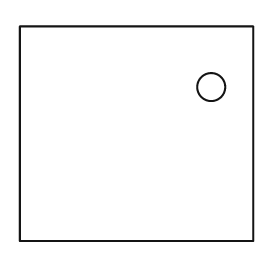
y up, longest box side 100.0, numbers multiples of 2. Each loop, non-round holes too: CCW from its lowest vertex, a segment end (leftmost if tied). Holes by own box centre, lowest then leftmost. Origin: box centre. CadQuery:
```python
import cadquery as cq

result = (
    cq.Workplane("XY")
    .moveTo(-50.0, -46.0)
    .lineTo(50.0, -46.0)
    .lineTo(50.0, 46.0)
    .lineTo(-50.0, 46.0)
    .close()
    .moveTo(32.0, 20.0)
    .circle(6.0)
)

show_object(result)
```